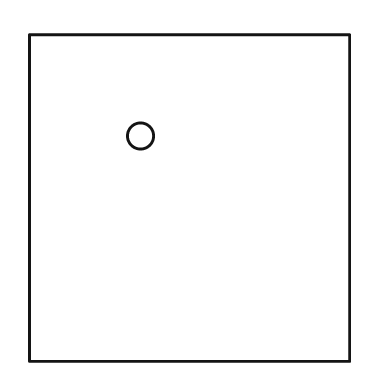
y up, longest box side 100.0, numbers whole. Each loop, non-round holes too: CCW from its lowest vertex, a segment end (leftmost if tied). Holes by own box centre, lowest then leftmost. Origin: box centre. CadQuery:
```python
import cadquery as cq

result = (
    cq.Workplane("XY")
    .moveTo(-49.0, -50.0)
    .lineTo(49.0, -50.0)
    .lineTo(49.0, 50.0)
    .lineTo(-49.0, 50.0)
    .close()
    .moveTo(-15.0, 19.0)
    .circle(4.0)
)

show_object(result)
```